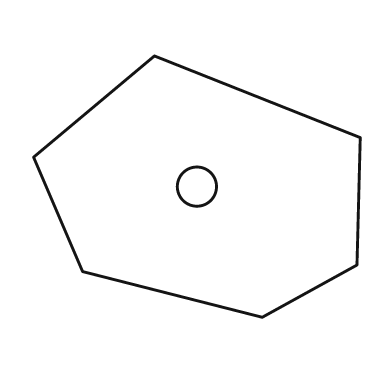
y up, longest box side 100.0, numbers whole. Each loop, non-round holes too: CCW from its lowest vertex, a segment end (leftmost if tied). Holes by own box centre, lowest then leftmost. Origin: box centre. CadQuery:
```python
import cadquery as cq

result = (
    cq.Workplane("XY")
    .moveTo(20.0, -40.0)
    .lineTo(49.0, -24.0)
    .lineTo(50.0, 15.0)
    .lineTo(-13.0, 40.0)
    .lineTo(-50.0, 9.0)
    .lineTo(-35.0, -26.0)
    .close()
    .moveTo(0.0, 0.0)
    .circle(6.0)
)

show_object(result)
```